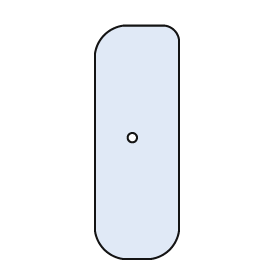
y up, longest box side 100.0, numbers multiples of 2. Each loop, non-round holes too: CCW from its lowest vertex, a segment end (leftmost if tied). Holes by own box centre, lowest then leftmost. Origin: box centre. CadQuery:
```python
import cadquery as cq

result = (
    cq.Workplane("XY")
    .moveTo(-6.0, -50.0)
    .lineTo(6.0, -50.0)
    .threePointArc((14.0, -46.0), (18.0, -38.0))
    .lineTo(18.0, 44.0)
    .threePointArc((16.0, 48.0), (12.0, 50.0))
    .lineTo(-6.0, 50.0)
    .threePointArc((-14.0, 46.0), (-18.0, 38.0))
    .lineTo(-18.0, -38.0)
    .threePointArc((-14.0, -46.0), (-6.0, -50.0))
    .close()
    .moveTo(-2.0, 2.0)
    .circle(2.0)
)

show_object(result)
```